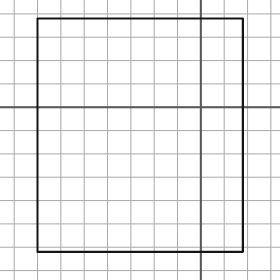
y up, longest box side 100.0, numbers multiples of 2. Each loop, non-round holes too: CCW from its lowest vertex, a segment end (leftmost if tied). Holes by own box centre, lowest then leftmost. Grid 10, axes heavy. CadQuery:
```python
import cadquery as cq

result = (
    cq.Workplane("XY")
    .moveTo(-70.0, -62.0)
    .lineTo(18.0, -62.0)
    .lineTo(18.0, 38.0)
    .lineTo(-70.0, 38.0)
    .close()
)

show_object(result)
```